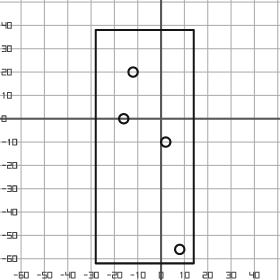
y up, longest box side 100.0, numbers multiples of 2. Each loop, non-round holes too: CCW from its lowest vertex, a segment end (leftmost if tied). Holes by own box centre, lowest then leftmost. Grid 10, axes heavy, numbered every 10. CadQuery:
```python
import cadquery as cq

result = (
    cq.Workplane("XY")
    .moveTo(-28.0, -62.0)
    .lineTo(14.0, -62.0)
    .lineTo(14.0, 38.0)
    .lineTo(-28.0, 38.0)
    .close()
    .moveTo(8.0, -56.0)
    .circle(2.0)
    .moveTo(2.0, -10.0)
    .circle(2.0)
    .moveTo(-16.0, 0.0)
    .circle(2.0)
    .moveTo(-12.0, 20.0)
    .circle(2.0)
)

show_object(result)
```